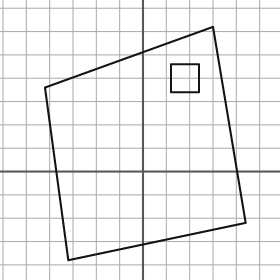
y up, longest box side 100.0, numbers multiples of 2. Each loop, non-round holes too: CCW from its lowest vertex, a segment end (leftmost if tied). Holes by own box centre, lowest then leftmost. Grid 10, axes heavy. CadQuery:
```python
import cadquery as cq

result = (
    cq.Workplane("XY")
    .moveTo(-32.0, -38.0)
    .lineTo(44.0, -22.0)
    .lineTo(30.0, 62.0)
    .lineTo(-42.0, 36.0)
    .close()
    .moveTo(12.0, 34.0)
    .lineTo(24.0, 34.0)
    .lineTo(24.0, 46.0)
    .lineTo(12.0, 46.0)
    .close()
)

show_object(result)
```